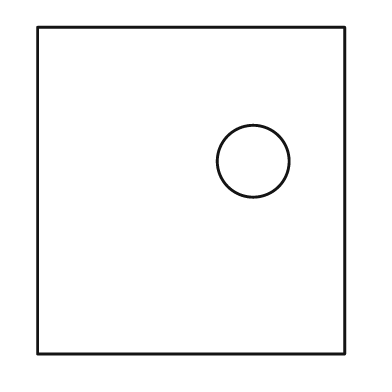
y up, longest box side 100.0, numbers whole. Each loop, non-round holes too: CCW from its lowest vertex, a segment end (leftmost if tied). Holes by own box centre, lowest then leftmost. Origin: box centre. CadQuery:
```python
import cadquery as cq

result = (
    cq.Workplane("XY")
    .moveTo(-47.0, -50.0)
    .lineTo(47.0, -50.0)
    .lineTo(47.0, 50.0)
    .lineTo(-47.0, 50.0)
    .close()
    .moveTo(19.0, 9.0)
    .circle(11.0)
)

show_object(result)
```